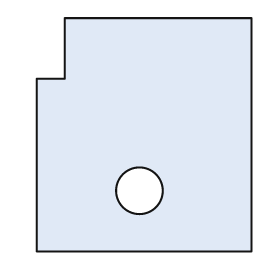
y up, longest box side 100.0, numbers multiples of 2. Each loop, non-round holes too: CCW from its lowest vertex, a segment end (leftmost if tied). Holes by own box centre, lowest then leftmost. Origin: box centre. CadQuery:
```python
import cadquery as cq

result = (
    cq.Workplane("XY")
    .moveTo(-46.0, -50.0)
    .lineTo(46.0, -50.0)
    .lineTo(46.0, 50.0)
    .lineTo(-34.0, 50.0)
    .lineTo(-34.0, 24.0)
    .lineTo(-46.0, 24.0)
    .close()
    .moveTo(-2.0, -24.0)
    .circle(10.0)
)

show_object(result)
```